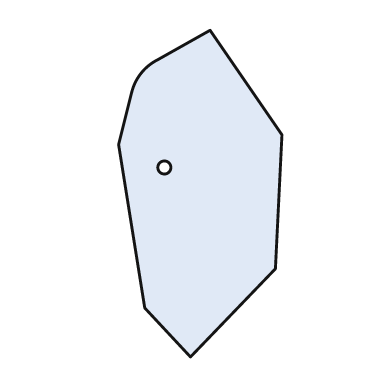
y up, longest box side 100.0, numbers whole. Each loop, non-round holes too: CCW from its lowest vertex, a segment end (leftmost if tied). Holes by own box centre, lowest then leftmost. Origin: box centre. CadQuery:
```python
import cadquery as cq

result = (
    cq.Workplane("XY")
    .moveTo(-3.0, -50.0)
    .lineTo(23.0, -23.0)
    .lineTo(25.0, 18.0)
    .lineTo(3.0, 50.0)
    .lineTo(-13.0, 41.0)
    .threePointArc((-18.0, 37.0), (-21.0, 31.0))
    .lineTo(-25.0, 15.0)
    .lineTo(-17.0, -35.0)
    .close()
    .moveTo(-11.0, 8.0)
    .circle(2.0)
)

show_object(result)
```